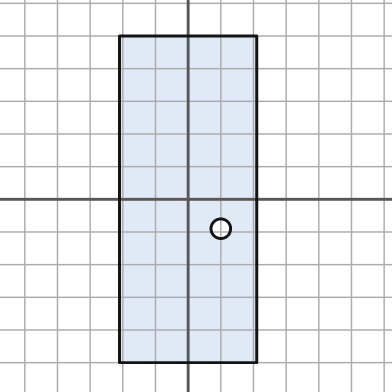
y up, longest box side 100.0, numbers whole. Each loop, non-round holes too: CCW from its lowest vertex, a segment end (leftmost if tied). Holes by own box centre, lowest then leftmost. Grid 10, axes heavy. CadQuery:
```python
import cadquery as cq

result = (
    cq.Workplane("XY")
    .moveTo(-21.0, -50.0)
    .lineTo(21.0, -50.0)
    .lineTo(21.0, 50.0)
    .lineTo(-21.0, 50.0)
    .close()
    .moveTo(10.0, -9.0)
    .circle(3.0)
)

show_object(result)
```